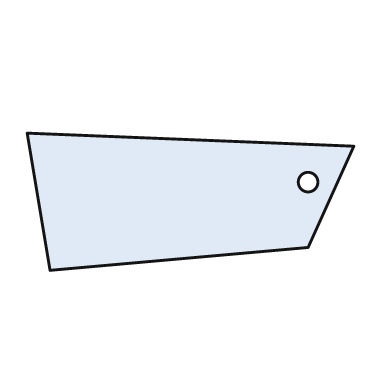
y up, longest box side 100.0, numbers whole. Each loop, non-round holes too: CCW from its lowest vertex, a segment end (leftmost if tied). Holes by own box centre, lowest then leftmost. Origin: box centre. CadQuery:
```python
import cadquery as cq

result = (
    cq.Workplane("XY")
    .moveTo(-43.0, -21.0)
    .lineTo(36.0, -14.0)
    .lineTo(50.0, 17.0)
    .lineTo(-50.0, 21.0)
    .close()
    .moveTo(36.0, 6.0)
    .circle(3.0)
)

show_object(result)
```